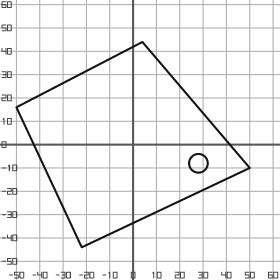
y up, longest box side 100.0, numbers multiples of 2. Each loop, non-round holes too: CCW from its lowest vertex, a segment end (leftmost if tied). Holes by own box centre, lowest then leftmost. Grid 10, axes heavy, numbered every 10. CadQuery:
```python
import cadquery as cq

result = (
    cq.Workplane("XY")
    .moveTo(-22.0, -44.0)
    .lineTo(50.0, -10.0)
    .lineTo(4.0, 44.0)
    .lineTo(-50.0, 16.0)
    .close()
    .moveTo(28.0, -8.0)
    .circle(4.0)
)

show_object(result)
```